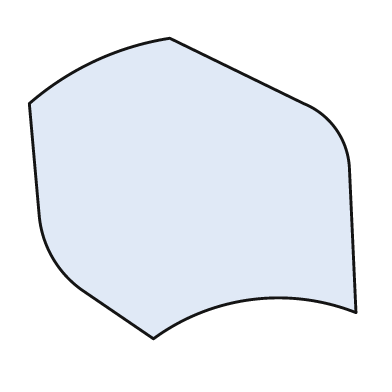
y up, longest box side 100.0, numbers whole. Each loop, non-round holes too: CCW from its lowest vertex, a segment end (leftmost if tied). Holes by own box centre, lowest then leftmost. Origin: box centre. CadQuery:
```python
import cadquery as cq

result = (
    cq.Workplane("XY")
    .moveTo(-12.0, -46.0)
    .threePointArc((18.0, -34.0), (50.0, -38.0))
    .lineTo(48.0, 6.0)
    .threePointArc((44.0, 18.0), (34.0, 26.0))
    .lineTo(-7.0, 46.0)
    .threePointArc((-30.0, 39.0), (-50.0, 26.0))
    .lineTo(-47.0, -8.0)
    .threePointArc((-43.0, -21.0), (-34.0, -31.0))
    .close()
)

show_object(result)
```